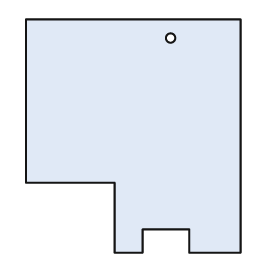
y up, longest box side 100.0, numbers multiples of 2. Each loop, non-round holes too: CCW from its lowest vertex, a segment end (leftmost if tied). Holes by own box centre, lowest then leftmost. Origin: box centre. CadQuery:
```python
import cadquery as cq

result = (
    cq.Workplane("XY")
    .moveTo(-8.0, -50.0)
    .lineTo(4.0, -50.0)
    .lineTo(4.0, -40.0)
    .lineTo(24.0, -40.0)
    .lineTo(24.0, -50.0)
    .lineTo(46.0, -50.0)
    .lineTo(46.0, 50.0)
    .lineTo(-46.0, 50.0)
    .lineTo(-46.0, -20.0)
    .lineTo(-8.0, -20.0)
    .close()
    .moveTo(16.0, 42.0)
    .circle(2.0)
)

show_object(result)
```